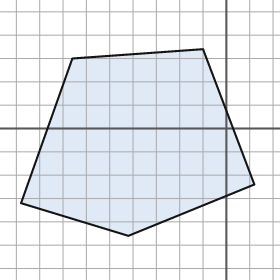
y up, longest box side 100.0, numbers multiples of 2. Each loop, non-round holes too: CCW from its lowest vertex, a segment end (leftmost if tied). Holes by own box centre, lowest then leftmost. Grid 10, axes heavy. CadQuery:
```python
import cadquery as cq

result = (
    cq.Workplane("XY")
    .moveTo(-42.0, -46.0)
    .lineTo(12.0, -24.0)
    .lineTo(-10.0, 34.0)
    .lineTo(-66.0, 30.0)
    .lineTo(-88.0, -32.0)
    .close()
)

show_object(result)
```